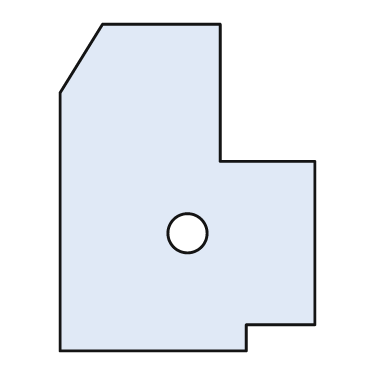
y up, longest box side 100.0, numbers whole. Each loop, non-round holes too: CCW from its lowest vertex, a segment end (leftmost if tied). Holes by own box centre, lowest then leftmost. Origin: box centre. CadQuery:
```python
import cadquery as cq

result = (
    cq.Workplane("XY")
    .moveTo(-39.0, -50.0)
    .lineTo(18.0, -50.0)
    .lineTo(18.0, -42.0)
    .lineTo(39.0, -42.0)
    .lineTo(39.0, 8.0)
    .lineTo(10.0, 8.0)
    .lineTo(10.0, 50.0)
    .lineTo(-26.0, 50.0)
    .lineTo(-39.0, 29.0)
    .close()
    .moveTo(0.0, -14.0)
    .circle(6.0)
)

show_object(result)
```